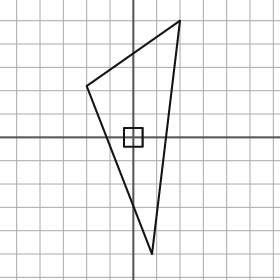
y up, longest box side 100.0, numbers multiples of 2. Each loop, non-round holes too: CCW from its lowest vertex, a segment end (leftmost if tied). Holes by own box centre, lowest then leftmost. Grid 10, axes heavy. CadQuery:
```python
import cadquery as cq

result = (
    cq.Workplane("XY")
    .moveTo(8.0, -50.0)
    .lineTo(20.0, 50.0)
    .lineTo(-20.0, 22.0)
    .close()
    .moveTo(-4.0, -4.0)
    .lineTo(4.0, -4.0)
    .lineTo(4.0, 4.0)
    .lineTo(-4.0, 4.0)
    .close()
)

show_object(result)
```